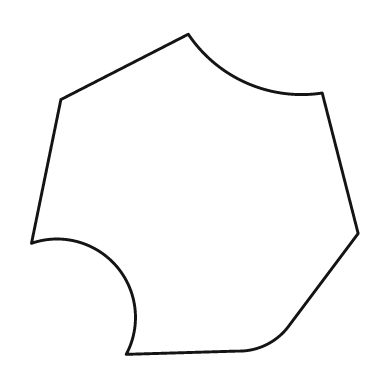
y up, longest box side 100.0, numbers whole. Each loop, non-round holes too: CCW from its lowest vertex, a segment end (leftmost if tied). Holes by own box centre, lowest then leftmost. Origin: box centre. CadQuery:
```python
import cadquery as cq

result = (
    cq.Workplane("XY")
    .moveTo(-21.0, -49.0)
    .lineTo(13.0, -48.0)
    .threePointArc((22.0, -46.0), (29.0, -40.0))
    .lineTo(50.0, -12.0)
    .lineTo(39.0, 31.0)
    .threePointArc((16.0, 34.0), (-2.0, 49.0))
    .lineTo(-41.0, 29.0)
    .lineTo(-50.0, -15.0)
    .threePointArc((-24.0, -22.0), (-21.0, -49.0))
    .close()
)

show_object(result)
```